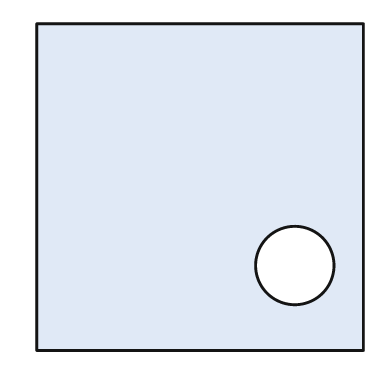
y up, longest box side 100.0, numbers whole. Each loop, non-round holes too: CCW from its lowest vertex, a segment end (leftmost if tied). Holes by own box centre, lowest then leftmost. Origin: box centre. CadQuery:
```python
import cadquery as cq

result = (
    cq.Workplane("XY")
    .moveTo(-50.0, -50.0)
    .lineTo(50.0, -50.0)
    .lineTo(50.0, 50.0)
    .lineTo(-50.0, 50.0)
    .close()
    .moveTo(29.0, -24.0)
    .circle(12.0)
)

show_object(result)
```